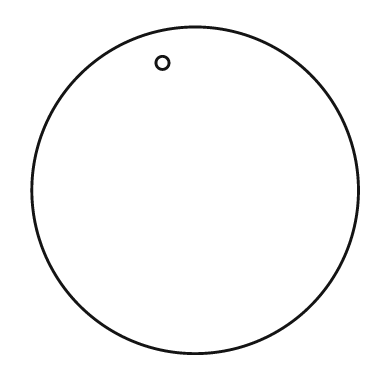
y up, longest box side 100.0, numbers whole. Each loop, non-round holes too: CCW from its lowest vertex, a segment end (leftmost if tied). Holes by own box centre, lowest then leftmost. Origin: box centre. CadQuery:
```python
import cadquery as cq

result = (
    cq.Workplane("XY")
    .moveTo(0.0, 0.0)
    .circle(50.0)
    .moveTo(-10.0, 39.0)
    .circle(2.0)
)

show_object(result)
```